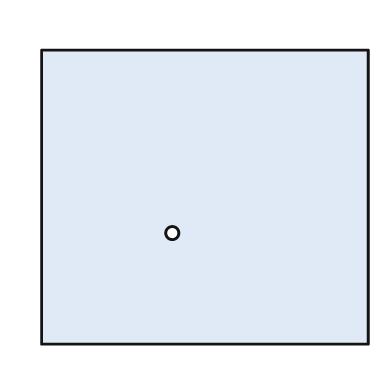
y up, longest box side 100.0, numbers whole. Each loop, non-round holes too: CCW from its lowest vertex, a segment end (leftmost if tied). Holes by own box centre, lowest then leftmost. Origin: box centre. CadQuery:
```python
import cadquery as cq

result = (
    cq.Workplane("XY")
    .moveTo(-50.0, -45.0)
    .lineTo(50.0, -45.0)
    .lineTo(50.0, 45.0)
    .lineTo(-50.0, 45.0)
    .close()
    .moveTo(-10.0, -11.0)
    .circle(2.0)
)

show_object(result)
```